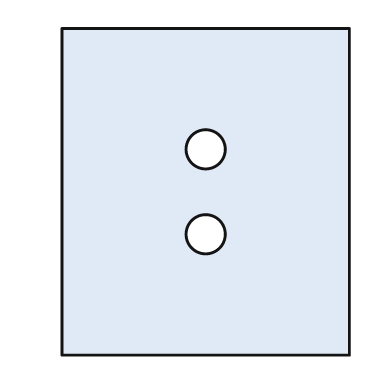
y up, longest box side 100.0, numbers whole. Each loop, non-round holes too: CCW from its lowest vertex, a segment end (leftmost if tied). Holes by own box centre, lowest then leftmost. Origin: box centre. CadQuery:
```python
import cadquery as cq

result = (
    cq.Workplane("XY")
    .moveTo(-44.0, -50.0)
    .lineTo(44.0, -50.0)
    .lineTo(44.0, 50.0)
    .lineTo(-44.0, 50.0)
    .close()
    .moveTo(0.0, -13.0)
    .circle(6.0)
    .moveTo(0.0, 13.0)
    .circle(6.0)
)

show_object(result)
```